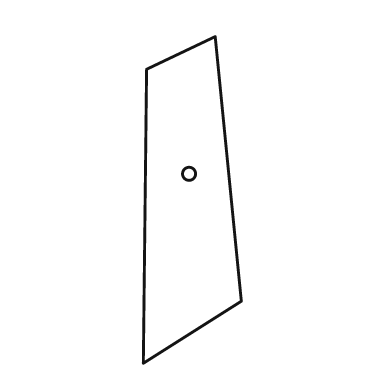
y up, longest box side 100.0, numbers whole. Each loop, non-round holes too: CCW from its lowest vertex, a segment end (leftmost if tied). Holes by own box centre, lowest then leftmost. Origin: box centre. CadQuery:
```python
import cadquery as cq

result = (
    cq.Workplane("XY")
    .moveTo(-15.0, -50.0)
    .lineTo(15.0, -31.0)
    .lineTo(7.0, 50.0)
    .lineTo(-14.0, 40.0)
    .close()
    .moveTo(-1.0, 8.0)
    .circle(2.0)
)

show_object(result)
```